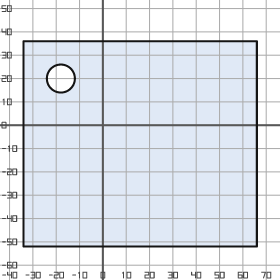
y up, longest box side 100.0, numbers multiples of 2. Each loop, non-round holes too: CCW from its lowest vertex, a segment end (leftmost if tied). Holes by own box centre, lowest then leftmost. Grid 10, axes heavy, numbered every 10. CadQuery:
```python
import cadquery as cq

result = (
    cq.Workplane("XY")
    .moveTo(-34.0, -52.0)
    .lineTo(66.0, -52.0)
    .lineTo(66.0, 36.0)
    .lineTo(-34.0, 36.0)
    .close()
    .moveTo(-18.0, 20.0)
    .circle(6.0)
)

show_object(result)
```